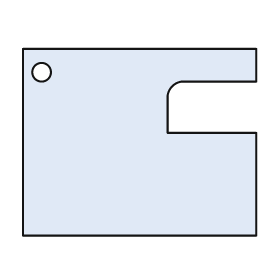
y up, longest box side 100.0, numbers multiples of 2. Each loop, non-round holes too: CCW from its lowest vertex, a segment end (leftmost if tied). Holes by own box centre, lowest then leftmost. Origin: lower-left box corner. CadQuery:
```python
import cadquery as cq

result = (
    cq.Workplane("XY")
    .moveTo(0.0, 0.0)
    .lineTo(100.0, 0.0)
    .lineTo(100.0, 44.0)
    .lineTo(62.0, 44.0)
    .lineTo(62.0, 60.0)
    .threePointArc((64.0, 64.0), (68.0, 66.0))
    .lineTo(100.0, 66.0)
    .lineTo(100.0, 80.0)
    .lineTo(0.0, 80.0)
    .close()
    .moveTo(8.0, 70.0)
    .circle(4.0)
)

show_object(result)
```